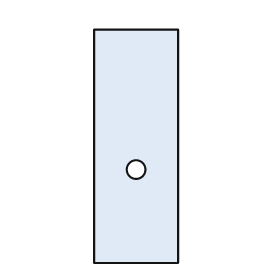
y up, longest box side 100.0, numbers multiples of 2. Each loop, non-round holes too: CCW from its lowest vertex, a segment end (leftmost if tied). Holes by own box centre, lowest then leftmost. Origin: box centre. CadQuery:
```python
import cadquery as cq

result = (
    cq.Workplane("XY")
    .moveTo(-18.0, -50.0)
    .lineTo(18.0, -50.0)
    .lineTo(18.0, 50.0)
    .lineTo(-18.0, 50.0)
    .close()
    .moveTo(0.0, -10.0)
    .circle(4.0)
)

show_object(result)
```